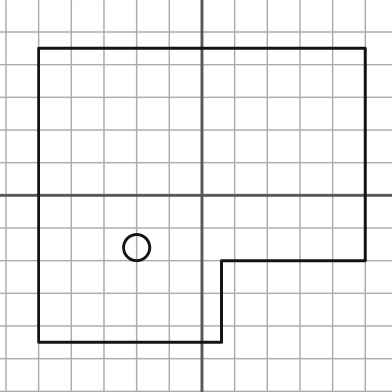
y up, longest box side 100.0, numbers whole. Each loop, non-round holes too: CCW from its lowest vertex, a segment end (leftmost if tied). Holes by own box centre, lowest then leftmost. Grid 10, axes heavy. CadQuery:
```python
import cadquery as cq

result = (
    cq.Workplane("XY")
    .moveTo(-50.0, -45.0)
    .lineTo(6.0, -45.0)
    .lineTo(6.0, -20.0)
    .lineTo(50.0, -20.0)
    .lineTo(50.0, 45.0)
    .lineTo(-50.0, 45.0)
    .close()
    .moveTo(-20.0, -16.0)
    .circle(4.0)
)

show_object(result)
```